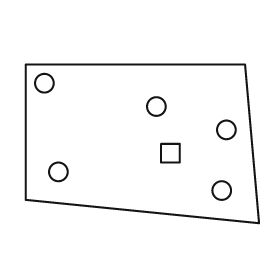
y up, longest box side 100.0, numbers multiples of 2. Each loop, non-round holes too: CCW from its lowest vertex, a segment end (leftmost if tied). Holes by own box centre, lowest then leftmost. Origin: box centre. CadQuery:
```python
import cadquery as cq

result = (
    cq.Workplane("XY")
    .moveTo(50.0, -34.0)
    .lineTo(44.0, 34.0)
    .lineTo(-50.0, 34.0)
    .lineTo(-50.0, -24.0)
    .close()
    .moveTo(34.0, -20.0)
    .circle(4.0)
    .moveTo(-36.0, -12.0)
    .circle(4.0)
    .moveTo(8.0, -8.0)
    .lineTo(16.0, -8.0)
    .lineTo(16.0, 0.0)
    .lineTo(8.0, 0.0)
    .close()
    .moveTo(36.0, 6.0)
    .circle(4.0)
    .moveTo(6.0, 16.0)
    .circle(4.0)
    .moveTo(-42.0, 26.0)
    .circle(4.0)
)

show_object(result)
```